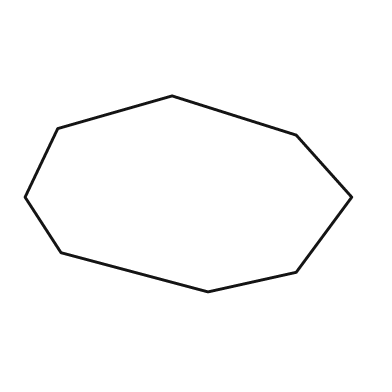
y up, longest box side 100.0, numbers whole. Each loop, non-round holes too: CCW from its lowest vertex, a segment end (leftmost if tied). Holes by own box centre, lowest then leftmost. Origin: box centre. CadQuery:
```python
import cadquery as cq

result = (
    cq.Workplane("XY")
    .moveTo(6.0, -30.0)
    .lineTo(33.0, -24.0)
    .lineTo(50.0, -1.0)
    .lineTo(33.0, 18.0)
    .lineTo(-5.0, 30.0)
    .lineTo(-40.0, 20.0)
    .lineTo(-50.0, -1.0)
    .lineTo(-39.0, -18.0)
    .close()
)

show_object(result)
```